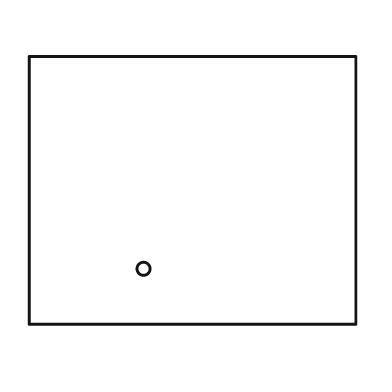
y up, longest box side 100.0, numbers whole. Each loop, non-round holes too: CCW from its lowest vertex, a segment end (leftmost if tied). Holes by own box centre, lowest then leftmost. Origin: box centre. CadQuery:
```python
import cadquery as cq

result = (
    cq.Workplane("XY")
    .moveTo(-50.0, -41.0)
    .lineTo(50.0, -41.0)
    .lineTo(50.0, 41.0)
    .lineTo(-50.0, 41.0)
    .close()
    .moveTo(-15.0, -24.0)
    .circle(2.0)
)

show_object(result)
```